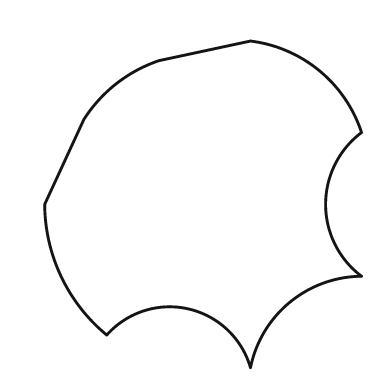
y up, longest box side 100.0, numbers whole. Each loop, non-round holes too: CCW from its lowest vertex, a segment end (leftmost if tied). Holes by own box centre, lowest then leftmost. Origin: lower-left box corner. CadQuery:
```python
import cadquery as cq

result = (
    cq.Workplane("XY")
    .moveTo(63.0, 0.0)
    .threePointArc((75.0, 20.0), (97.0, 28.0))
    .threePointArc((86.0, 50.0), (97.0, 72.0))
    .threePointArc((84.0, 91.0), (63.0, 100.0))
    .lineTo(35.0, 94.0)
    .threePointArc((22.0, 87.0), (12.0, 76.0))
    .lineTo(0.0, 50.0)
    .threePointArc((5.0, 28.0), (19.0, 10.0))
    .threePointArc((44.0, 18.0), (63.0, 0.0))
    .close()
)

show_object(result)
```